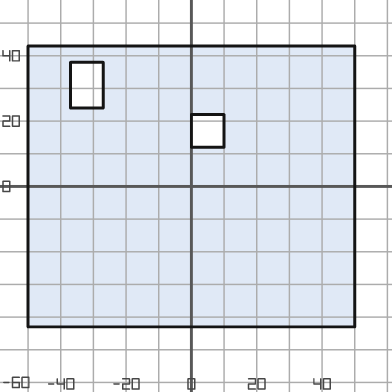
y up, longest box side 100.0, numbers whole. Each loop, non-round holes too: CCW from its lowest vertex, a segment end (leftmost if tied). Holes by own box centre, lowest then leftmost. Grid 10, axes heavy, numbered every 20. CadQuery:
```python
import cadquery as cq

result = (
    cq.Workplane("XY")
    .moveTo(-50.0, -43.0)
    .lineTo(50.0, -43.0)
    .lineTo(50.0, 43.0)
    .lineTo(-50.0, 43.0)
    .close()
    .moveTo(0.0, 12.0)
    .lineTo(10.0, 12.0)
    .lineTo(10.0, 22.0)
    .lineTo(0.0, 22.0)
    .close()
    .moveTo(-37.0, 24.0)
    .lineTo(-27.0, 24.0)
    .lineTo(-27.0, 38.0)
    .lineTo(-37.0, 38.0)
    .close()
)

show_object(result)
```